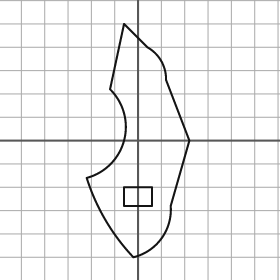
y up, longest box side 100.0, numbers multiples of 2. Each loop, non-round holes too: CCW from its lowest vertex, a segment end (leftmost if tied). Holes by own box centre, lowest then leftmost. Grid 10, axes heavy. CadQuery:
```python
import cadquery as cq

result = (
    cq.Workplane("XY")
    .moveTo(-2.0, -50.0)
    .threePointArc((10.0, -42.0), (14.0, -28.0))
    .lineTo(22.0, 0.0)
    .lineTo(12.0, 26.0)
    .threePointArc((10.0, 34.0), (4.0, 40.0))
    .lineTo(-6.0, 50.0)
    .lineTo(-12.0, 22.0)
    .threePointArc((-6.0, 0.0), (-22.0, -16.0))
    .threePointArc((-14.0, -34.0), (-2.0, -50.0))
    .close()
    .moveTo(-6.0, -28.0)
    .lineTo(6.0, -28.0)
    .lineTo(6.0, -20.0)
    .lineTo(-6.0, -20.0)
    .close()
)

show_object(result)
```